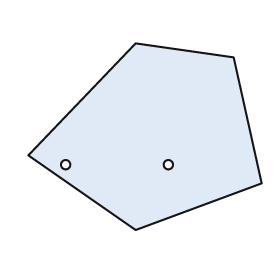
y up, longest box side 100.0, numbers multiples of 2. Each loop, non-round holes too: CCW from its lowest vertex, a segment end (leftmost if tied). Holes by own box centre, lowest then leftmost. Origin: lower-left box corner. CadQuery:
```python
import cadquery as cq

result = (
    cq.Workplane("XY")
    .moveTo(46.0, 0.0)
    .lineTo(100.0, 20.0)
    .lineTo(88.0, 74.0)
    .lineTo(46.0, 80.0)
    .lineTo(0.0, 32.0)
    .close()
    .moveTo(16.0, 28.0)
    .circle(2.0)
    .moveTo(60.0, 28.0)
    .circle(2.0)
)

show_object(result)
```